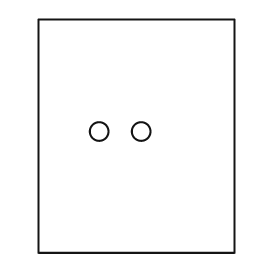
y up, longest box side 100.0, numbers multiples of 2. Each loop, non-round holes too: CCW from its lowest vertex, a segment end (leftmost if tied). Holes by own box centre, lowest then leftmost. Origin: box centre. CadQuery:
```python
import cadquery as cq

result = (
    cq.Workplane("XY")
    .moveTo(-42.0, -50.0)
    .lineTo(42.0, -50.0)
    .lineTo(42.0, 50.0)
    .lineTo(-42.0, 50.0)
    .close()
    .moveTo(-16.0, 2.0)
    .circle(4.0)
    .moveTo(2.0, 2.0)
    .circle(4.0)
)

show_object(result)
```